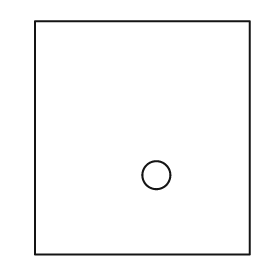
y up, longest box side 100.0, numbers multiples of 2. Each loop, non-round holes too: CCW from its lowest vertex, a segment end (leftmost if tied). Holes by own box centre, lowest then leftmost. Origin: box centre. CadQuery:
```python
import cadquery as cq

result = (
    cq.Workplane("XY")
    .moveTo(-46.0, -50.0)
    .lineTo(46.0, -50.0)
    .lineTo(46.0, 50.0)
    .lineTo(-46.0, 50.0)
    .close()
    .moveTo(6.0, -16.0)
    .circle(6.0)
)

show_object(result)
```